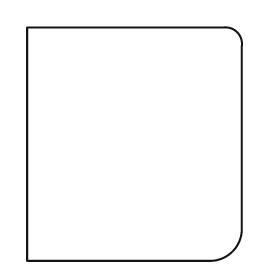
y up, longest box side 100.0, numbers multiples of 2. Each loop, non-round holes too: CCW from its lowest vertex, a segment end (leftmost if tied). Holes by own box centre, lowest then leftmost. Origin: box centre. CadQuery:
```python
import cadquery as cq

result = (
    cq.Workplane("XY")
    .moveTo(-46.0, -50.0)
    .lineTo(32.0, -50.0)
    .threePointArc((42.0, -46.0), (46.0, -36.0))
    .lineTo(46.0, 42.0)
    .threePointArc((44.0, 48.0), (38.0, 50.0))
    .lineTo(-46.0, 50.0)
    .close()
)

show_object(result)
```